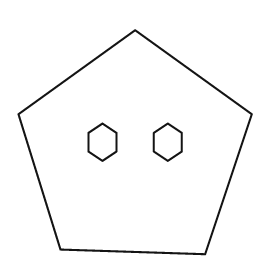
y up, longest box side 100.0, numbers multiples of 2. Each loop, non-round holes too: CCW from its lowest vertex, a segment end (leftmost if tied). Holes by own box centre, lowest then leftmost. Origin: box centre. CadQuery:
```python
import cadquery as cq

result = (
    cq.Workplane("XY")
    .moveTo(30.0, -48.0)
    .lineTo(50.0, 12.0)
    .lineTo(0.0, 48.0)
    .lineTo(-50.0, 12.0)
    .lineTo(-32.0, -46.0)
    .close()
    .moveTo(-14.0, -8.0)
    .lineTo(-8.0, -4.0)
    .lineTo(-8.0, 4.0)
    .lineTo(-14.0, 8.0)
    .lineTo(-20.0, 4.0)
    .lineTo(-20.0, -4.0)
    .close()
    .moveTo(14.0, -8.0)
    .lineTo(20.0, -4.0)
    .lineTo(20.0, 4.0)
    .lineTo(14.0, 8.0)
    .lineTo(8.0, 4.0)
    .lineTo(8.0, -4.0)
    .close()
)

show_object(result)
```